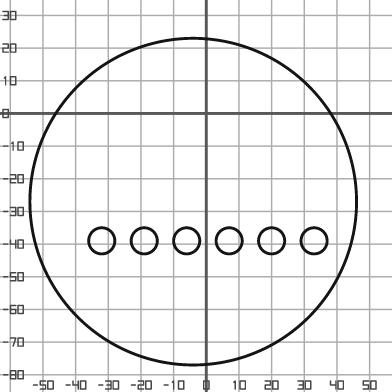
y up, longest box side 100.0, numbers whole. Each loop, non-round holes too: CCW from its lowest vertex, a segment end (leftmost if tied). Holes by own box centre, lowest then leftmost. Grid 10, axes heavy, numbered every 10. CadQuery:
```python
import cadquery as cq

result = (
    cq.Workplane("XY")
    .moveTo(-4.0, -27.0)
    .circle(50.0)
    .moveTo(-32.0, -39.0)
    .circle(4.0)
    .moveTo(-19.0, -39.0)
    .circle(4.0)
    .moveTo(-6.0, -39.0)
    .circle(4.0)
    .moveTo(7.0, -39.0)
    .circle(4.0)
    .moveTo(20.0, -39.0)
    .circle(4.0)
    .moveTo(33.0, -39.0)
    .circle(4.0)
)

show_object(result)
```